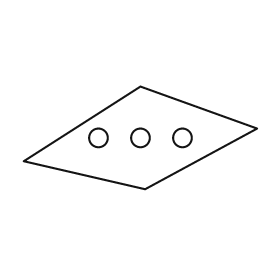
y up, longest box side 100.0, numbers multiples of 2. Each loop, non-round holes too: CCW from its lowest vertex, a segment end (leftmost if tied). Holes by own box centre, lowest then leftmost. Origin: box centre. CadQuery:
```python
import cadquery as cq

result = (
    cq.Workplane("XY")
    .moveTo(2.0, -22.0)
    .lineTo(50.0, 4.0)
    .lineTo(0.0, 22.0)
    .lineTo(-50.0, -10.0)
    .close()
    .moveTo(-18.0, 0.0)
    .circle(4.0)
    .moveTo(0.0, 0.0)
    .circle(4.0)
    .moveTo(18.0, 0.0)
    .circle(4.0)
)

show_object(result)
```